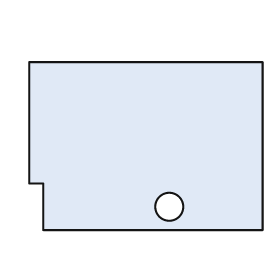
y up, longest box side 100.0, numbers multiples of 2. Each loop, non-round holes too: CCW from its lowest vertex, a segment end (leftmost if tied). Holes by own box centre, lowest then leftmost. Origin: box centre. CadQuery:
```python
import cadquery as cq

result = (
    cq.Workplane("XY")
    .moveTo(-44.0, -36.0)
    .lineTo(50.0, -36.0)
    .lineTo(50.0, 36.0)
    .lineTo(-50.0, 36.0)
    .lineTo(-50.0, -16.0)
    .lineTo(-44.0, -16.0)
    .close()
    .moveTo(10.0, -26.0)
    .circle(6.0)
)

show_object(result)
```